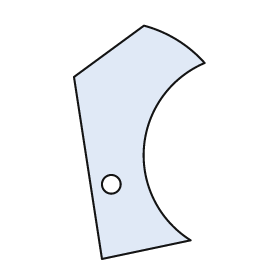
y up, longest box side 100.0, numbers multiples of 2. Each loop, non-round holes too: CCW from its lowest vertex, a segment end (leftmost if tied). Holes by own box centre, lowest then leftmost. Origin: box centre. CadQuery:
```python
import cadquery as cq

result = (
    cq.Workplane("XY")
    .moveTo(-16.0, -50.0)
    .lineTo(22.0, -42.0)
    .threePointArc((2.0, -2.0), (28.0, 34.0))
    .threePointArc((16.0, 44.0), (2.0, 50.0))
    .lineTo(-28.0, 28.0)
    .close()
    .moveTo(-12.0, -18.0)
    .circle(4.0)
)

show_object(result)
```